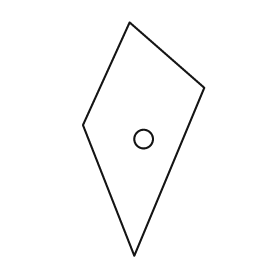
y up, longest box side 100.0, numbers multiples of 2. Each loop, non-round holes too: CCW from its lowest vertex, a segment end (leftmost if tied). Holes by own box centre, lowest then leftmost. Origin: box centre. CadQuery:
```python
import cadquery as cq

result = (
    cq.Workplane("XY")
    .moveTo(-4.0, -50.0)
    .lineTo(26.0, 22.0)
    .lineTo(-6.0, 50.0)
    .lineTo(-26.0, 6.0)
    .close()
    .moveTo(0.0, 0.0)
    .circle(4.0)
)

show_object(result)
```